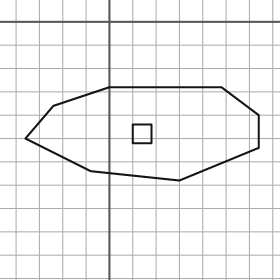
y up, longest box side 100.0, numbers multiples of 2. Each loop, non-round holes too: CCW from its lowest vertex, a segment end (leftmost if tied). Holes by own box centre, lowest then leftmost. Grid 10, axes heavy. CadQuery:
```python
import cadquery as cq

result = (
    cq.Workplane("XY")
    .moveTo(30.0, -68.0)
    .lineTo(64.0, -54.0)
    .lineTo(64.0, -40.0)
    .lineTo(48.0, -28.0)
    .lineTo(0.0, -28.0)
    .lineTo(-24.0, -36.0)
    .lineTo(-36.0, -50.0)
    .lineTo(-8.0, -64.0)
    .close()
    .moveTo(10.0, -52.0)
    .lineTo(18.0, -52.0)
    .lineTo(18.0, -44.0)
    .lineTo(10.0, -44.0)
    .close()
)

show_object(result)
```